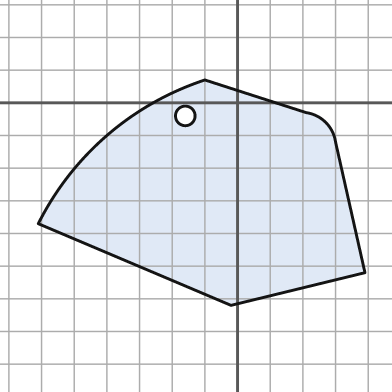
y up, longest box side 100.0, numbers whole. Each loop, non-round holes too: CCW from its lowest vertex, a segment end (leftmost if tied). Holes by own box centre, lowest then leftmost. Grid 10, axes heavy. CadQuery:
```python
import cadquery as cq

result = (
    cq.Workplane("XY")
    .moveTo(-2.0, -62.0)
    .lineTo(39.0, -52.0)
    .lineTo(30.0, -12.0)
    .threePointArc((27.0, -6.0), (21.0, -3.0))
    .lineTo(-10.0, 7.0)
    .threePointArc((-40.0, -10.0), (-61.0, -37.0))
    .close()
    .moveTo(-16.0, -4.0)
    .circle(3.0)
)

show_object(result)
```